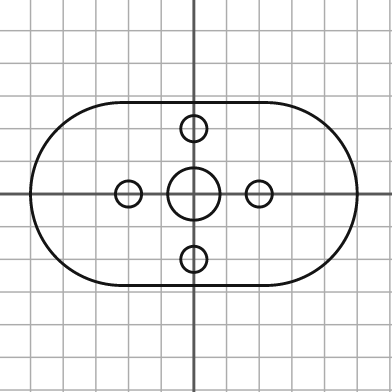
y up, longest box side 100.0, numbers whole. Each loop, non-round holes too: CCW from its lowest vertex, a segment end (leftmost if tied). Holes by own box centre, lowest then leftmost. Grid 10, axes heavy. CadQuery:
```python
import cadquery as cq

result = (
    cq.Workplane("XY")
    .moveTo(-22.0, -28.0)
    .lineTo(22.0, -28.0)
    .threePointArc((50.0, 0.0), (22.0, 28.0))
    .lineTo(-22.0, 28.0)
    .threePointArc((-50.0, 0.0), (-22.0, -28.0))
    .close()
    .moveTo(0.0, -20.0)
    .circle(4.0)
    .moveTo(-20.0, 0.0)
    .circle(4.0)
    .moveTo(0.0, 0.0)
    .circle(8.0)
    .moveTo(20.0, 0.0)
    .circle(4.0)
    .moveTo(0.0, 20.0)
    .circle(4.0)
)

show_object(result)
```